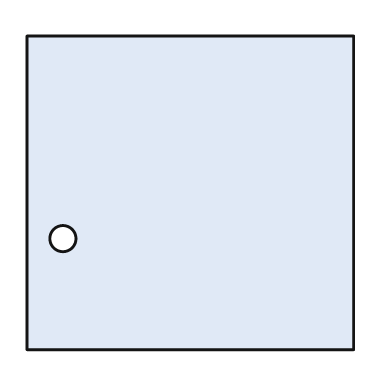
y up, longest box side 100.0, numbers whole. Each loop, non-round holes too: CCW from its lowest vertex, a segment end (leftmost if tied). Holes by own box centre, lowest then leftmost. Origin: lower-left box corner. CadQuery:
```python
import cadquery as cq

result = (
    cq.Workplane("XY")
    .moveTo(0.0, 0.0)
    .lineTo(100.0, 0.0)
    .lineTo(100.0, 96.0)
    .lineTo(0.0, 96.0)
    .close()
    .moveTo(11.0, 34.0)
    .circle(4.0)
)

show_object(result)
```